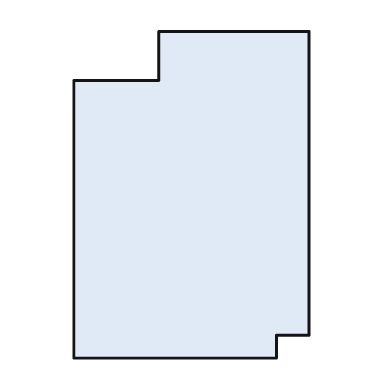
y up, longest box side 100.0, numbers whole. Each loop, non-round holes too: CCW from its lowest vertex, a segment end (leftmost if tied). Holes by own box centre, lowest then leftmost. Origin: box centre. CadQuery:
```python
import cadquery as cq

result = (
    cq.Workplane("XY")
    .moveTo(-36.0, -50.0)
    .lineTo(26.0, -50.0)
    .lineTo(26.0, -43.0)
    .lineTo(36.0, -43.0)
    .lineTo(36.0, 50.0)
    .lineTo(-10.0, 50.0)
    .lineTo(-10.0, 35.0)
    .lineTo(-36.0, 35.0)
    .close()
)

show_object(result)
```